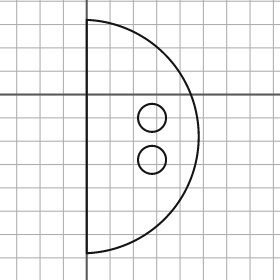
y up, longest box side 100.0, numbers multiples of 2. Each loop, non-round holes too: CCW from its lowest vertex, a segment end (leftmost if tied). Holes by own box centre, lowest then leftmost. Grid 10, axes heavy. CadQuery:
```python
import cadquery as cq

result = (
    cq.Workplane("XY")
    .moveTo(0.0, -68.0)
    .threePointArc((48.0, -18.0), (0.0, 32.0))
    .close()
    .moveTo(28.0, -28.0)
    .circle(6.0)
    .moveTo(28.0, -10.0)
    .circle(6.0)
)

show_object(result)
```